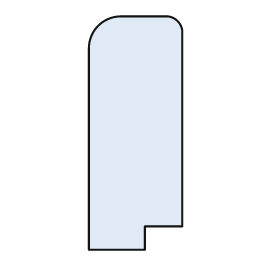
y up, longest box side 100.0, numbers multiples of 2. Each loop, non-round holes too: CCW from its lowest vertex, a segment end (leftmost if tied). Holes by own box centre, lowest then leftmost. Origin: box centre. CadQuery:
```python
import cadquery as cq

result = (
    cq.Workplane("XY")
    .moveTo(-20.0, -50.0)
    .lineTo(4.0, -50.0)
    .lineTo(4.0, -40.0)
    .lineTo(20.0, -40.0)
    .lineTo(20.0, 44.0)
    .threePointArc((18.0, 48.0), (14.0, 50.0))
    .lineTo(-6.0, 50.0)
    .threePointArc((-16.0, 46.0), (-20.0, 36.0))
    .close()
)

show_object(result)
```